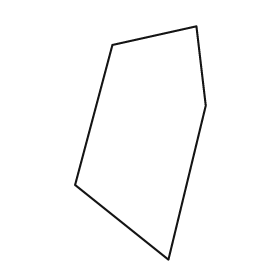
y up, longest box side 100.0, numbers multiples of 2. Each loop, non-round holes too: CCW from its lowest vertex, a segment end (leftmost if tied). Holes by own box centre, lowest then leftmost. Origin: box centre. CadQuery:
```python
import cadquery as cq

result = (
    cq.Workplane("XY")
    .moveTo(12.0, -50.0)
    .lineTo(28.0, 16.0)
    .lineTo(24.0, 50.0)
    .lineTo(-12.0, 42.0)
    .lineTo(-28.0, -18.0)
    .close()
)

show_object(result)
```